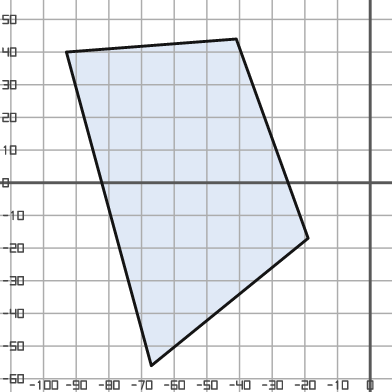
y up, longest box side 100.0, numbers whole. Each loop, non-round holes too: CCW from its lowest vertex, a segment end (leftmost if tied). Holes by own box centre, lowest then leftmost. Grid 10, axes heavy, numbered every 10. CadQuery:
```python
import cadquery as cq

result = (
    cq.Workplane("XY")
    .moveTo(-67.0, -56.0)
    .lineTo(-19.0, -17.0)
    .lineTo(-41.0, 44.0)
    .lineTo(-93.0, 40.0)
    .close()
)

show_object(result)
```